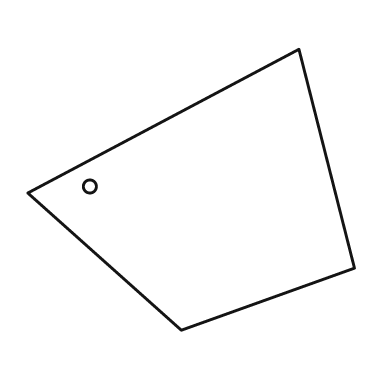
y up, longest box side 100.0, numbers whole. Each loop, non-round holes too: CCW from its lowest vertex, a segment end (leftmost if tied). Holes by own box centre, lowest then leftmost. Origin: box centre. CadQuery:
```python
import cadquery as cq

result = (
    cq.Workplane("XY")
    .moveTo(-3.0, -43.0)
    .lineTo(50.0, -24.0)
    .lineTo(33.0, 43.0)
    .lineTo(-50.0, -1.0)
    .close()
    .moveTo(-31.0, 1.0)
    .circle(2.0)
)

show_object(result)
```